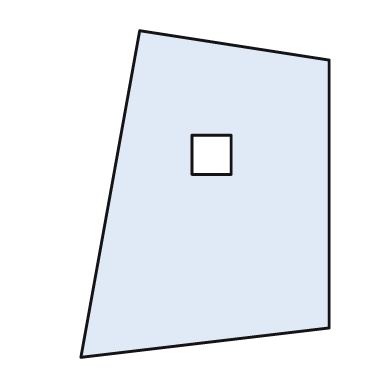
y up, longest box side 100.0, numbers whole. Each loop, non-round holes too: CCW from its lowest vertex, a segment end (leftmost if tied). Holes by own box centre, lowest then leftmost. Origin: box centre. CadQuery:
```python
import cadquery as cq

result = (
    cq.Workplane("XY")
    .moveTo(-38.0, -50.0)
    .lineTo(38.0, -41.0)
    .lineTo(38.0, 41.0)
    .lineTo(-20.0, 50.0)
    .close()
    .moveTo(-4.0, 6.0)
    .lineTo(8.0, 6.0)
    .lineTo(8.0, 18.0)
    .lineTo(-4.0, 18.0)
    .close()
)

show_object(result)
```